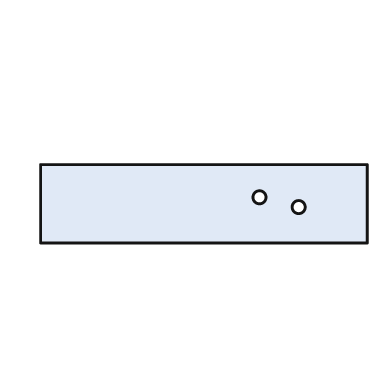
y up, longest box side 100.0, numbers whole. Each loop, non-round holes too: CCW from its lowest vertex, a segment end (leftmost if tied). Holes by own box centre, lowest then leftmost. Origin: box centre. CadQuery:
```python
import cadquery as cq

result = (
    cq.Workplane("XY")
    .moveTo(-50.0, -12.0)
    .lineTo(50.0, -12.0)
    .lineTo(50.0, 12.0)
    .lineTo(-50.0, 12.0)
    .close()
    .moveTo(29.0, -1.0)
    .circle(2.0)
    .moveTo(17.0, 2.0)
    .circle(2.0)
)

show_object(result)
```